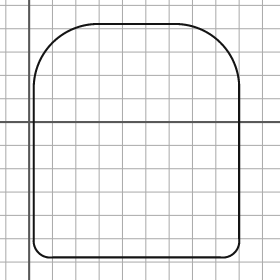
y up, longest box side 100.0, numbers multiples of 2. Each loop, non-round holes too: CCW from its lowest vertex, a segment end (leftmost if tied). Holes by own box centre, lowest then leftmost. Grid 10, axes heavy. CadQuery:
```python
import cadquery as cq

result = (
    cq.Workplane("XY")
    .moveTo(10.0, -58.0)
    .lineTo(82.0, -58.0)
    .threePointArc((88.0, -56.0), (90.0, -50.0))
    .lineTo(90.0, 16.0)
    .threePointArc((82.0, 34.0), (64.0, 42.0))
    .lineTo(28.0, 42.0)
    .threePointArc((10.0, 34.0), (2.0, 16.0))
    .lineTo(2.0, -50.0)
    .threePointArc((4.0, -56.0), (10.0, -58.0))
    .close()
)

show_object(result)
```